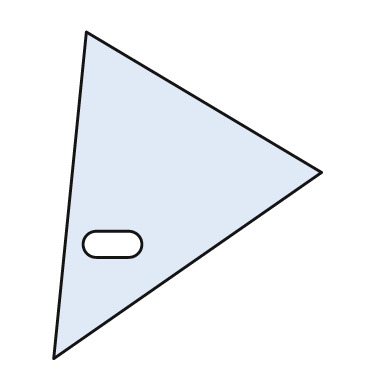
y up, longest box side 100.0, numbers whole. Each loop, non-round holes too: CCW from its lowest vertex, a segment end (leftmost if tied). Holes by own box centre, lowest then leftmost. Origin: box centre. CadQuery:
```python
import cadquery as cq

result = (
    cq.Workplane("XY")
    .moveTo(-41.0, -50.0)
    .lineTo(41.0, 7.0)
    .lineTo(-31.0, 50.0)
    .close()
    .moveTo(-28.0, -19.0)
    .lineTo(-18.0, -19.0)
    .threePointArc((-14.0, -15.0), (-18.0, -11.0))
    .lineTo(-28.0, -11.0)
    .threePointArc((-32.0, -15.0), (-28.0, -19.0))
    .close()
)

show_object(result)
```